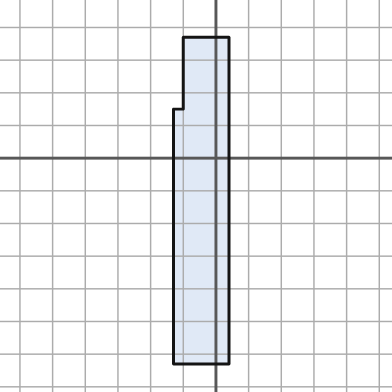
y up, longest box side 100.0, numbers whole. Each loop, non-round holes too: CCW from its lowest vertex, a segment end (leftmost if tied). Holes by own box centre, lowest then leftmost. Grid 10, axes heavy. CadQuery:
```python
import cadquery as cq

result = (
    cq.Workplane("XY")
    .moveTo(-13.0, -63.0)
    .lineTo(4.0, -63.0)
    .lineTo(4.0, 37.0)
    .lineTo(-10.0, 37.0)
    .lineTo(-10.0, 15.0)
    .lineTo(-13.0, 15.0)
    .close()
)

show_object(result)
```